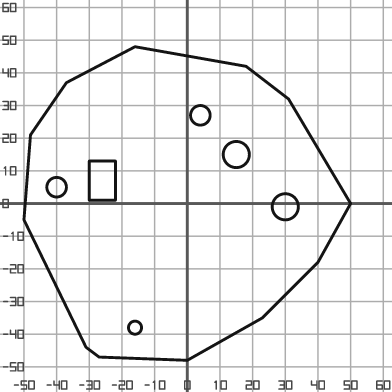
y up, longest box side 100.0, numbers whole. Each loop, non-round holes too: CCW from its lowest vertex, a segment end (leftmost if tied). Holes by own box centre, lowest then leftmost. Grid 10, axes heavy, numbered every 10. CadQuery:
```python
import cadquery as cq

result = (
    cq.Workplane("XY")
    .moveTo(0.0, -48.0)
    .lineTo(23.0, -35.0)
    .lineTo(40.0, -18.0)
    .lineTo(50.0, 0.0)
    .lineTo(31.0, 32.0)
    .lineTo(18.0, 42.0)
    .lineTo(-16.0, 48.0)
    .lineTo(-37.0, 37.0)
    .lineTo(-48.0, 21.0)
    .lineTo(-50.0, -5.0)
    .lineTo(-31.0, -44.0)
    .lineTo(-27.0, -47.0)
    .close()
    .moveTo(-16.0, -38.0)
    .circle(2.0)
    .moveTo(30.0, -1.0)
    .circle(4.0)
    .moveTo(-40.0, 5.0)
    .circle(3.0)
    .moveTo(-30.0, 1.0)
    .lineTo(-22.0, 1.0)
    .lineTo(-22.0, 13.0)
    .lineTo(-30.0, 13.0)
    .close()
    .moveTo(15.0, 15.0)
    .circle(4.0)
    .moveTo(4.0, 27.0)
    .circle(3.0)
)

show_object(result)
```